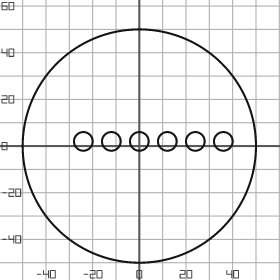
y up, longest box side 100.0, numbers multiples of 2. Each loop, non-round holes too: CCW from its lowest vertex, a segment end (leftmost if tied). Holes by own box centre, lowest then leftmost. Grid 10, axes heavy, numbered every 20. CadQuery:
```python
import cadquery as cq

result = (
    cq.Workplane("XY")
    .moveTo(0.0, 0.0)
    .circle(50.0)
    .moveTo(-24.0, 2.0)
    .circle(4.0)
    .moveTo(-12.0, 2.0)
    .circle(4.0)
    .moveTo(0.0, 2.0)
    .circle(4.0)
    .moveTo(12.0, 2.0)
    .circle(4.0)
    .moveTo(24.0, 2.0)
    .circle(4.0)
    .moveTo(36.0, 2.0)
    .circle(4.0)
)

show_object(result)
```